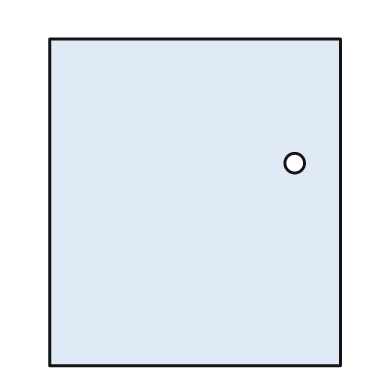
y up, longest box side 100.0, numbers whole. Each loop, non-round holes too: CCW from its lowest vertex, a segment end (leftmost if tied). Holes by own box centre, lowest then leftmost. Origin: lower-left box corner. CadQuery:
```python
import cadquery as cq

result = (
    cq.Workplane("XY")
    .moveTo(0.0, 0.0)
    .lineTo(89.0, 0.0)
    .lineTo(89.0, 100.0)
    .lineTo(0.0, 100.0)
    .close()
    .moveTo(75.0, 62.0)
    .circle(3.0)
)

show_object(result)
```